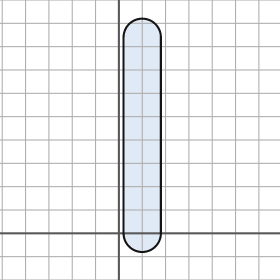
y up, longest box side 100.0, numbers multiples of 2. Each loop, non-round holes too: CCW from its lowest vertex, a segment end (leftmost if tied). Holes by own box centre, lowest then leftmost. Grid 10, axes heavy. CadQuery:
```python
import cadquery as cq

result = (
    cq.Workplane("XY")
    .moveTo(2.0, 0.0)
    .threePointArc((10.0, -8.0), (18.0, 0.0))
    .lineTo(18.0, 84.0)
    .threePointArc((10.0, 92.0), (2.0, 84.0))
    .close()
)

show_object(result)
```